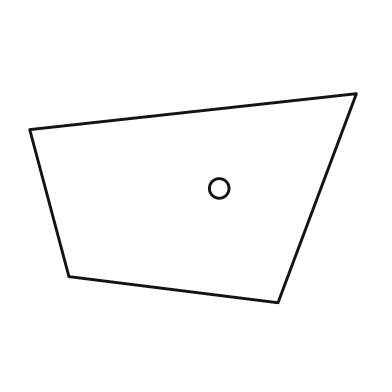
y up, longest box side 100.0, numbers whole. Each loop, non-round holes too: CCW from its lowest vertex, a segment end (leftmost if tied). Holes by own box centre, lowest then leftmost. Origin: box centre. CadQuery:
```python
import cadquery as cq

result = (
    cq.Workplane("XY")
    .moveTo(26.0, -32.0)
    .lineTo(50.0, 32.0)
    .lineTo(-50.0, 21.0)
    .lineTo(-38.0, -24.0)
    .close()
    .moveTo(8.0, 3.0)
    .circle(3.0)
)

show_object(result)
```